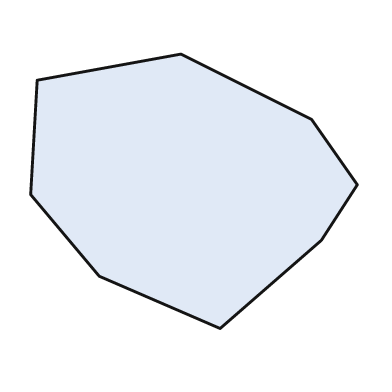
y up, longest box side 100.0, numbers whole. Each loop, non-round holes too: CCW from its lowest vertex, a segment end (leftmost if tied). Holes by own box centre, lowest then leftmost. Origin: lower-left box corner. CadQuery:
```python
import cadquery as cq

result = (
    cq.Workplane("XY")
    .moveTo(58.0, 0.0)
    .lineTo(89.0, 27.0)
    .lineTo(100.0, 44.0)
    .lineTo(86.0, 64.0)
    .lineTo(46.0, 84.0)
    .lineTo(2.0, 76.0)
    .lineTo(0.0, 41.0)
    .lineTo(21.0, 16.0)
    .close()
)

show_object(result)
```